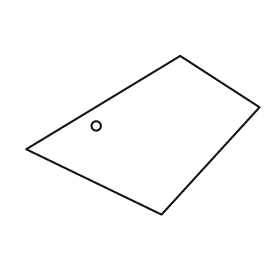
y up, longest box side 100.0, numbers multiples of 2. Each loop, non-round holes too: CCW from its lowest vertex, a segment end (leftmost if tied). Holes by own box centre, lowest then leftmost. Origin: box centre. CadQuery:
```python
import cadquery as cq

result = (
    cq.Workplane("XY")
    .moveTo(8.0, -34.0)
    .lineTo(50.0, 12.0)
    .lineTo(16.0, 34.0)
    .lineTo(-50.0, -6.0)
    .close()
    .moveTo(-20.0, 4.0)
    .circle(2.0)
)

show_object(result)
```